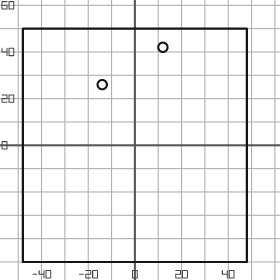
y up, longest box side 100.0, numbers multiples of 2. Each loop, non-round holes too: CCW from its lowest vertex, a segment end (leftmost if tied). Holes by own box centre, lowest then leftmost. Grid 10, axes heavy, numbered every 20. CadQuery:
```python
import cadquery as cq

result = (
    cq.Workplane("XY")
    .moveTo(-48.0, -50.0)
    .lineTo(48.0, -50.0)
    .lineTo(48.0, 50.0)
    .lineTo(-48.0, 50.0)
    .close()
    .moveTo(-14.0, 26.0)
    .circle(2.0)
    .moveTo(12.0, 42.0)
    .circle(2.0)
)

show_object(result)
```